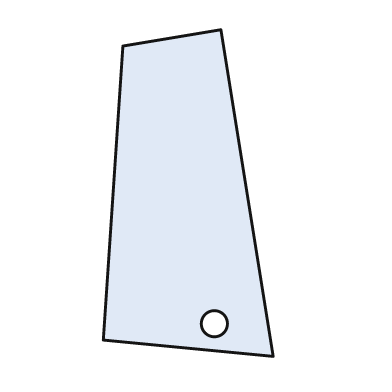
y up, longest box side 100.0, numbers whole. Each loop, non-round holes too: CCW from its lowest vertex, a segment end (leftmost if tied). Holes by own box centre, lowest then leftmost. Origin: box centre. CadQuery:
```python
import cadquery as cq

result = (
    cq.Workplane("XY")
    .moveTo(26.0, -50.0)
    .lineTo(10.0, 50.0)
    .lineTo(-20.0, 45.0)
    .lineTo(-26.0, -45.0)
    .close()
    .moveTo(8.0, -40.0)
    .circle(4.0)
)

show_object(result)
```